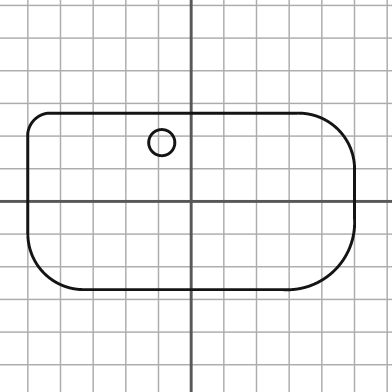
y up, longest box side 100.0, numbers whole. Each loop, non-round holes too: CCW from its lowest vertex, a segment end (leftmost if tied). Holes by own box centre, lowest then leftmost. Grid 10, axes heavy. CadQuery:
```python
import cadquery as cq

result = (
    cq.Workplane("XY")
    .moveTo(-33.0, -27.0)
    .lineTo(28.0, -27.0)
    .threePointArc((44.0, -21.0), (50.0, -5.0))
    .lineTo(50.0, 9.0)
    .threePointArc((45.0, 22.0), (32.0, 27.0))
    .lineTo(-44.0, 27.0)
    .threePointArc((-48.0, 25.0), (-50.0, 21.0))
    .lineTo(-50.0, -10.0)
    .threePointArc((-45.0, -22.0), (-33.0, -27.0))
    .close()
    .moveTo(-9.0, 18.0)
    .circle(4.0)
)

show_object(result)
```